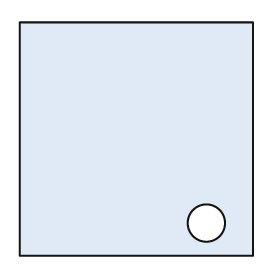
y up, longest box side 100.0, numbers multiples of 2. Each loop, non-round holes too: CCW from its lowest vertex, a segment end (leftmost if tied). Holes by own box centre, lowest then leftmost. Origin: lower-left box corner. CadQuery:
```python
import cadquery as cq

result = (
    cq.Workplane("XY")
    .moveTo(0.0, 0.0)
    .lineTo(100.0, 0.0)
    .lineTo(100.0, 100.0)
    .lineTo(0.0, 100.0)
    .close()
    .moveTo(80.0, 14.0)
    .circle(8.0)
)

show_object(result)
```